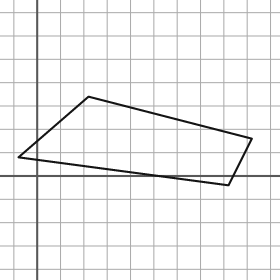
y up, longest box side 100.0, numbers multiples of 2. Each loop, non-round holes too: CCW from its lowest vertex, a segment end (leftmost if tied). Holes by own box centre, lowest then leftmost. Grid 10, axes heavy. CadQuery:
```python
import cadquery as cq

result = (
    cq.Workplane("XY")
    .moveTo(82.0, -4.0)
    .lineTo(92.0, 16.0)
    .lineTo(22.0, 34.0)
    .lineTo(-8.0, 8.0)
    .close()
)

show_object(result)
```